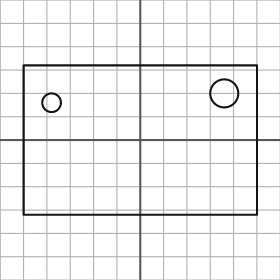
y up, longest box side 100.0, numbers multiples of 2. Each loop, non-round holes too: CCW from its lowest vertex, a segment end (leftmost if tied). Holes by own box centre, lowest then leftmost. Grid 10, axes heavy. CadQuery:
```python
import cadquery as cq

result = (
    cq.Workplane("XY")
    .moveTo(-50.0, -32.0)
    .lineTo(50.0, -32.0)
    .lineTo(50.0, 32.0)
    .lineTo(-50.0, 32.0)
    .close()
    .moveTo(-38.0, 16.0)
    .circle(4.0)
    .moveTo(36.0, 20.0)
    .circle(6.0)
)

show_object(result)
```